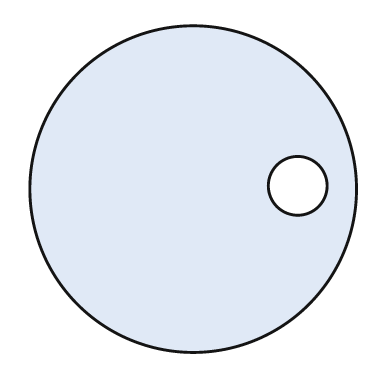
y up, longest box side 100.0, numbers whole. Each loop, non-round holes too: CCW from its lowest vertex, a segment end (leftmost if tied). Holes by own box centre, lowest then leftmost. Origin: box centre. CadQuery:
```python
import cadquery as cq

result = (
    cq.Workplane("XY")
    .moveTo(0.0, 0.0)
    .circle(50.0)
    .moveTo(32.0, 1.0)
    .circle(9.0)
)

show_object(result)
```